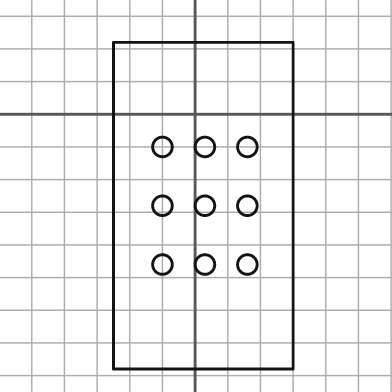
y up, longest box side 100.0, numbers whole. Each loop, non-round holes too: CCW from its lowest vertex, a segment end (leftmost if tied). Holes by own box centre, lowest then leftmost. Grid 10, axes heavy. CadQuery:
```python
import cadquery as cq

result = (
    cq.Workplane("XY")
    .moveTo(-25.0, -78.0)
    .lineTo(30.0, -78.0)
    .lineTo(30.0, 22.0)
    .lineTo(-25.0, 22.0)
    .close()
    .moveTo(-10.0, -46.0)
    .circle(3.0)
    .moveTo(3.0, -46.0)
    .circle(3.0)
    .moveTo(16.0, -46.0)
    .circle(3.0)
    .moveTo(-10.0, -28.0)
    .circle(3.0)
    .moveTo(3.0, -28.0)
    .circle(3.0)
    .moveTo(16.0, -28.0)
    .circle(3.0)
    .moveTo(-10.0, -10.0)
    .circle(3.0)
    .moveTo(3.0, -10.0)
    .circle(3.0)
    .moveTo(16.0, -10.0)
    .circle(3.0)
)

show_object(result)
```